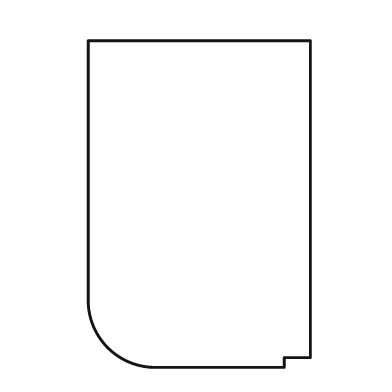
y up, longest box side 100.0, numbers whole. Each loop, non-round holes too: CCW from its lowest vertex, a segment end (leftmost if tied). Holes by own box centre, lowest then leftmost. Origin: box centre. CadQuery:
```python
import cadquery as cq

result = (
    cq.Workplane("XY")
    .moveTo(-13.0, -50.0)
    .lineTo(26.0, -50.0)
    .lineTo(26.0, -47.0)
    .lineTo(34.0, -47.0)
    .lineTo(34.0, 50.0)
    .lineTo(-34.0, 50.0)
    .lineTo(-34.0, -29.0)
    .threePointArc((-28.0, -44.0), (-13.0, -50.0))
    .close()
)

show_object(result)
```